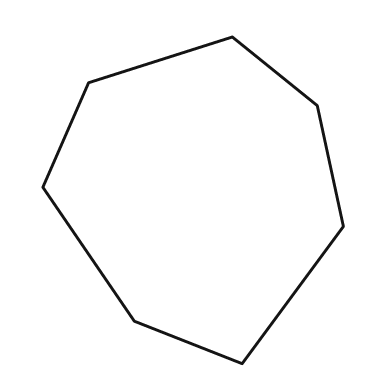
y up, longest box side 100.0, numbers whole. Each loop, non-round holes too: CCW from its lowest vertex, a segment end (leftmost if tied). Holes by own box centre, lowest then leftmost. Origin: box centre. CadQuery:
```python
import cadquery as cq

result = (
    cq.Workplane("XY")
    .moveTo(15.0, -50.0)
    .lineTo(46.0, -8.0)
    .lineTo(38.0, 29.0)
    .lineTo(12.0, 50.0)
    .lineTo(-32.0, 36.0)
    .lineTo(-46.0, 4.0)
    .lineTo(-18.0, -37.0)
    .close()
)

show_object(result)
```